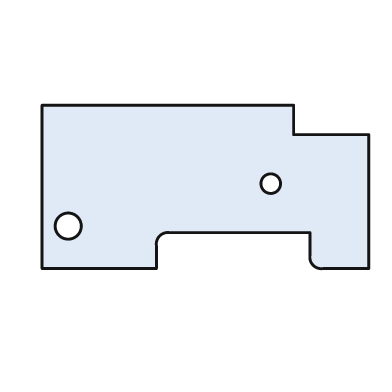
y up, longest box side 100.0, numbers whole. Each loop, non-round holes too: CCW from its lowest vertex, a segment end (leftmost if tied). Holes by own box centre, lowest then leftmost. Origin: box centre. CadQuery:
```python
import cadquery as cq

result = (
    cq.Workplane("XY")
    .moveTo(-50.0, -25.0)
    .lineTo(-15.0, -25.0)
    .lineTo(-15.0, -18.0)
    .threePointArc((-14.0, -15.0), (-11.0, -14.0))
    .lineTo(32.0, -14.0)
    .lineTo(32.0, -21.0)
    .threePointArc((33.0, -24.0), (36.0, -25.0))
    .lineTo(50.0, -25.0)
    .lineTo(50.0, 16.0)
    .lineTo(27.0, 16.0)
    .lineTo(27.0, 25.0)
    .lineTo(-50.0, 25.0)
    .close()
    .moveTo(-42.0, -12.0)
    .circle(4.0)
    .moveTo(20.0, 1.0)
    .circle(3.0)
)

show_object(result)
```